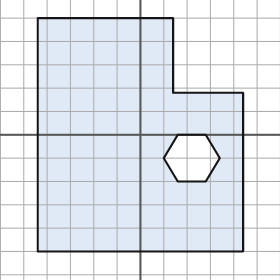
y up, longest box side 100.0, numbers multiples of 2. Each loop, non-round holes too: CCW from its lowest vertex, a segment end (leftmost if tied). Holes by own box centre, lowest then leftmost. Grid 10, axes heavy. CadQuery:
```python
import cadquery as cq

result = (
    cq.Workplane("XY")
    .moveTo(-44.0, -50.0)
    .lineTo(44.0, -50.0)
    .lineTo(44.0, 18.0)
    .lineTo(14.0, 18.0)
    .lineTo(14.0, 50.0)
    .lineTo(-44.0, 50.0)
    .close()
    .moveTo(16.0, -20.0)
    .lineTo(28.0, -20.0)
    .lineTo(34.0, -10.0)
    .lineTo(28.0, 0.0)
    .lineTo(16.0, 0.0)
    .lineTo(10.0, -10.0)
    .close()
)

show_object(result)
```